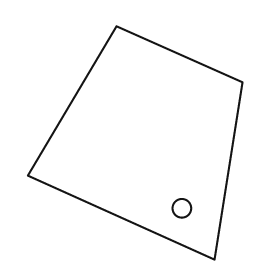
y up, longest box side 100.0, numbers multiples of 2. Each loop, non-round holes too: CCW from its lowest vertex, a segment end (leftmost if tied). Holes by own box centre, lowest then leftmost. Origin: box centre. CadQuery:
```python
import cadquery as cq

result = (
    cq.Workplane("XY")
    .moveTo(34.0, -50.0)
    .lineTo(46.0, 26.0)
    .lineTo(-8.0, 50.0)
    .lineTo(-46.0, -14.0)
    .close()
    .moveTo(20.0, -28.0)
    .circle(4.0)
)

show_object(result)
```